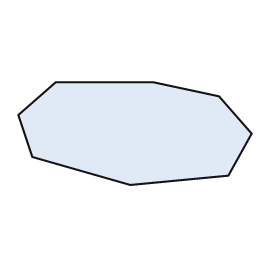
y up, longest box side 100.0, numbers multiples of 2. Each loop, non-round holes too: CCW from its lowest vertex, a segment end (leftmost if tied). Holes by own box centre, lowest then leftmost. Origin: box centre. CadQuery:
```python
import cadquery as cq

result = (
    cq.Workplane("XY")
    .moveTo(-2.0, -22.0)
    .lineTo(40.0, -18.0)
    .lineTo(50.0, 0.0)
    .lineTo(36.0, 16.0)
    .lineTo(8.0, 22.0)
    .lineTo(-34.0, 22.0)
    .lineTo(-50.0, 8.0)
    .lineTo(-44.0, -10.0)
    .close()
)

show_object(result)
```